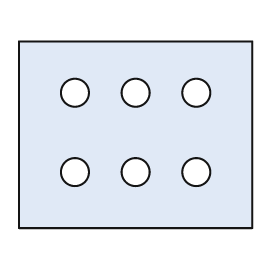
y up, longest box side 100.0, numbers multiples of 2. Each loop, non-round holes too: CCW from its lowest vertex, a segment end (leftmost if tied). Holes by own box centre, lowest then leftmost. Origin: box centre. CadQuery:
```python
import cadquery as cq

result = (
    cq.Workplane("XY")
    .moveTo(-50.0, -40.0)
    .lineTo(50.0, -40.0)
    .lineTo(50.0, 40.0)
    .lineTo(-50.0, 40.0)
    .close()
    .moveTo(-26.0, -16.0)
    .circle(6.0)
    .moveTo(0.0, -16.0)
    .circle(6.0)
    .moveTo(26.0, -16.0)
    .circle(6.0)
    .moveTo(-26.0, 18.0)
    .circle(6.0)
    .moveTo(0.0, 18.0)
    .circle(6.0)
    .moveTo(26.0, 18.0)
    .circle(6.0)
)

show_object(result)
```